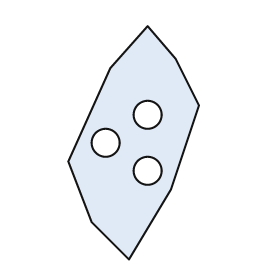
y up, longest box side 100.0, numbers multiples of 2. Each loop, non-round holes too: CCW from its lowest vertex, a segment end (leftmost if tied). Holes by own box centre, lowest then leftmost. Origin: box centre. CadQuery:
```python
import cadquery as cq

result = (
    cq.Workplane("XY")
    .moveTo(-2.0, -50.0)
    .lineTo(16.0, -20.0)
    .lineTo(28.0, 16.0)
    .lineTo(18.0, 36.0)
    .lineTo(6.0, 50.0)
    .lineTo(-10.0, 32.0)
    .lineTo(-28.0, -8.0)
    .lineTo(-18.0, -34.0)
    .close()
    .moveTo(6.0, -12.0)
    .circle(6.0)
    .moveTo(-12.0, 0.0)
    .circle(6.0)
    .moveTo(6.0, 12.0)
    .circle(6.0)
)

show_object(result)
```